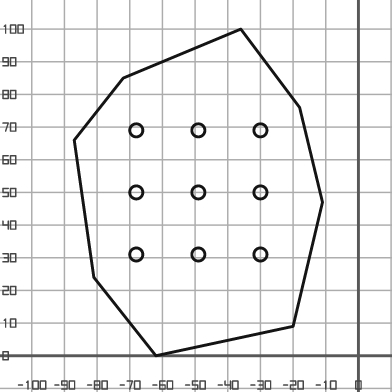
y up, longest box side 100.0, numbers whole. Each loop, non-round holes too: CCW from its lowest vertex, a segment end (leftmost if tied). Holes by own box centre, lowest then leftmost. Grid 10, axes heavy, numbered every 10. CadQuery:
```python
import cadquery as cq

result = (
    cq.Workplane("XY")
    .moveTo(-62.0, 0.0)
    .lineTo(-20.0, 9.0)
    .lineTo(-11.0, 47.0)
    .lineTo(-18.0, 76.0)
    .lineTo(-36.0, 100.0)
    .lineTo(-72.0, 85.0)
    .lineTo(-87.0, 66.0)
    .lineTo(-81.0, 24.0)
    .close()
    .moveTo(-68.0, 31.0)
    .circle(2.0)
    .moveTo(-49.0, 31.0)
    .circle(2.0)
    .moveTo(-30.0, 31.0)
    .circle(2.0)
    .moveTo(-68.0, 50.0)
    .circle(2.0)
    .moveTo(-49.0, 50.0)
    .circle(2.0)
    .moveTo(-30.0, 50.0)
    .circle(2.0)
    .moveTo(-68.0, 69.0)
    .circle(2.0)
    .moveTo(-49.0, 69.0)
    .circle(2.0)
    .moveTo(-30.0, 69.0)
    .circle(2.0)
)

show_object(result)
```